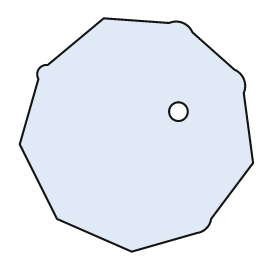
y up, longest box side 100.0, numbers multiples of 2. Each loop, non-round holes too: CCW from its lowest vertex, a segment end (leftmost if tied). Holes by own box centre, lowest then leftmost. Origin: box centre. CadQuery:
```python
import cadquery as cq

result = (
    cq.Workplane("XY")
    .moveTo(-2.0, -50.0)
    .lineTo(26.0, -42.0)
    .threePointArc((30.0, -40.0), (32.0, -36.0))
    .lineTo(50.0, -12.0)
    .lineTo(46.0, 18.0)
    .threePointArc((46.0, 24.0), (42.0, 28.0))
    .lineTo(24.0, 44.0)
    .threePointArc((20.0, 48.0), (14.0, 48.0))
    .lineTo(-14.0, 50.0)
    .lineTo(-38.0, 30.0)
    .threePointArc((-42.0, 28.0), (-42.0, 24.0))
    .lineTo(-50.0, -4.0)
    .lineTo(-34.0, -36.0)
    .close()
    .moveTo(18.0, 10.0)
    .circle(4.0)
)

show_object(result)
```